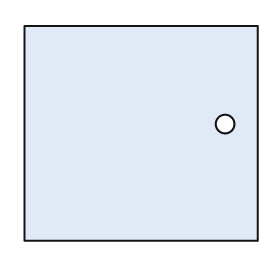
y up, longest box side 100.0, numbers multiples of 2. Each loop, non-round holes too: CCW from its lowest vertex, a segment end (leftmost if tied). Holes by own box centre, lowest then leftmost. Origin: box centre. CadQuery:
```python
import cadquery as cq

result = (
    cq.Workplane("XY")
    .moveTo(-50.0, -46.0)
    .lineTo(50.0, -46.0)
    .lineTo(50.0, 46.0)
    .lineTo(-50.0, 46.0)
    .close()
    .moveTo(36.0, 4.0)
    .circle(4.0)
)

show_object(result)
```